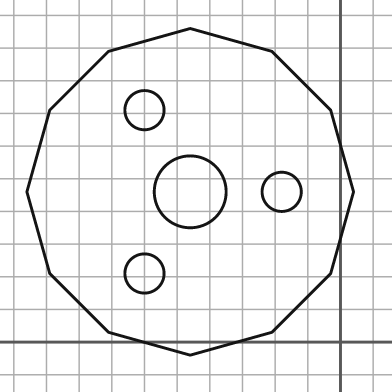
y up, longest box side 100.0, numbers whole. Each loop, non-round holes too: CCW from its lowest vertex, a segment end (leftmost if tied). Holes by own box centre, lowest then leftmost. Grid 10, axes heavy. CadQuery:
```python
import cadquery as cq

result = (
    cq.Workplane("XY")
    .moveTo(-46.0, -4.0)
    .lineTo(-21.0, 3.0)
    .lineTo(-3.0, 21.0)
    .lineTo(4.0, 46.0)
    .lineTo(-3.0, 71.0)
    .lineTo(-21.0, 89.0)
    .lineTo(-46.0, 96.0)
    .lineTo(-71.0, 89.0)
    .lineTo(-89.0, 71.0)
    .lineTo(-96.0, 46.0)
    .lineTo(-89.0, 21.0)
    .lineTo(-71.0, 3.0)
    .close()
    .moveTo(-60.0, 21.0)
    .circle(6.0)
    .moveTo(-46.0, 46.0)
    .circle(11.0)
    .moveTo(-18.0, 46.0)
    .circle(6.0)
    .moveTo(-60.0, 71.0)
    .circle(6.0)
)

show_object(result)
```